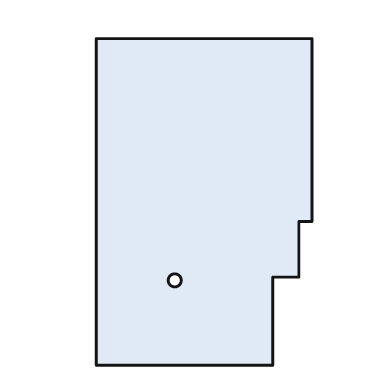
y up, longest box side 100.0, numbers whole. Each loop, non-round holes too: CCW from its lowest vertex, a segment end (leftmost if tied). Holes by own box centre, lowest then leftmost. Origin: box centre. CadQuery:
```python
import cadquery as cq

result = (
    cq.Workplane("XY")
    .moveTo(-33.0, -50.0)
    .lineTo(21.0, -50.0)
    .lineTo(21.0, -23.0)
    .lineTo(29.0, -23.0)
    .lineTo(29.0, -6.0)
    .lineTo(33.0, -6.0)
    .lineTo(33.0, 50.0)
    .lineTo(-33.0, 50.0)
    .close()
    .moveTo(-9.0, -24.0)
    .circle(2.0)
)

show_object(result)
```